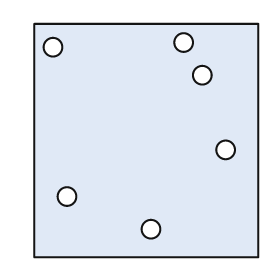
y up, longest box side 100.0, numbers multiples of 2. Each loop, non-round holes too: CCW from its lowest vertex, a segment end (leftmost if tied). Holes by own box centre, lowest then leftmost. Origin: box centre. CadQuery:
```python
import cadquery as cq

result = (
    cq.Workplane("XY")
    .moveTo(-48.0, -50.0)
    .lineTo(48.0, -50.0)
    .lineTo(48.0, 50.0)
    .lineTo(-48.0, 50.0)
    .close()
    .moveTo(2.0, -38.0)
    .circle(4.0)
    .moveTo(-34.0, -24.0)
    .circle(4.0)
    .moveTo(34.0, -4.0)
    .circle(4.0)
    .moveTo(24.0, 28.0)
    .circle(4.0)
    .moveTo(-40.0, 40.0)
    .circle(4.0)
    .moveTo(16.0, 42.0)
    .circle(4.0)
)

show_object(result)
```